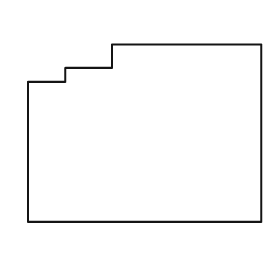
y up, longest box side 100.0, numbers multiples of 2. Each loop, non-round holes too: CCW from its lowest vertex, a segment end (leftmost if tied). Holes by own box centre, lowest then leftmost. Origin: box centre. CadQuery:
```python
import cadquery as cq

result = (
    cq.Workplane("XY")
    .moveTo(-50.0, -38.0)
    .lineTo(50.0, -38.0)
    .lineTo(50.0, 38.0)
    .lineTo(-14.0, 38.0)
    .lineTo(-14.0, 28.0)
    .lineTo(-34.0, 28.0)
    .lineTo(-34.0, 22.0)
    .lineTo(-50.0, 22.0)
    .close()
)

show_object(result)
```